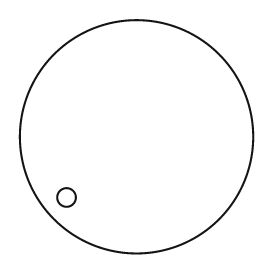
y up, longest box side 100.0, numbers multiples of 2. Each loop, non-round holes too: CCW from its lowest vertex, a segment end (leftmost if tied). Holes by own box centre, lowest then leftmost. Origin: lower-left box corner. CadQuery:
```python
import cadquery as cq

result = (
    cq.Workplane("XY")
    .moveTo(50.0, 50.0)
    .circle(50.0)
    .moveTo(20.0, 24.0)
    .circle(4.0)
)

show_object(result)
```